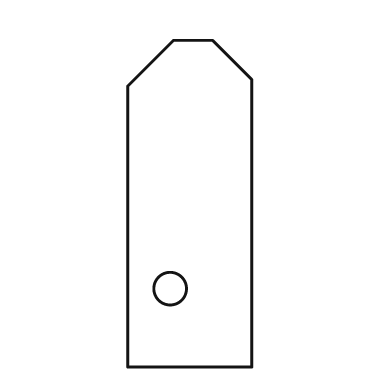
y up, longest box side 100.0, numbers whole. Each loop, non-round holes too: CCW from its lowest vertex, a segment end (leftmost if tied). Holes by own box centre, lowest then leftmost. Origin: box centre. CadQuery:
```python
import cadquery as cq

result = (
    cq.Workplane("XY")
    .moveTo(-19.0, -50.0)
    .lineTo(19.0, -50.0)
    .lineTo(19.0, 38.0)
    .lineTo(7.0, 50.0)
    .lineTo(-5.0, 50.0)
    .lineTo(-19.0, 36.0)
    .close()
    .moveTo(-6.0, -26.0)
    .circle(5.0)
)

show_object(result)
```